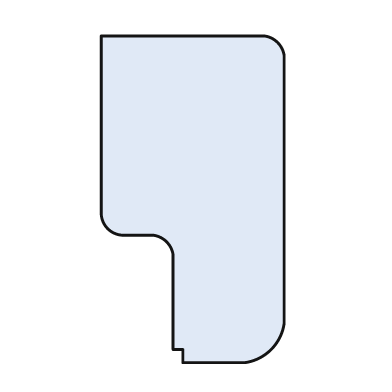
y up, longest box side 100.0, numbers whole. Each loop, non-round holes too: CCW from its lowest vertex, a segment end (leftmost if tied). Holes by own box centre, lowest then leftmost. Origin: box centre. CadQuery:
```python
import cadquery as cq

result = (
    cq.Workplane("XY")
    .moveTo(-3.0, -50.0)
    .lineTo(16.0, -50.0)
    .threePointArc((24.0, -46.0), (28.0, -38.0))
    .lineTo(28.0, 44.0)
    .threePointArc((26.0, 48.0), (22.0, 50.0))
    .lineTo(-28.0, 50.0)
    .lineTo(-28.0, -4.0)
    .threePointArc((-26.0, -9.0), (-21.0, -11.0))
    .lineTo(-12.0, -11.0)
    .threePointArc((-8.0, -13.0), (-6.0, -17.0))
    .lineTo(-6.0, -46.0)
    .lineTo(-3.0, -46.0)
    .close()
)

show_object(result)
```